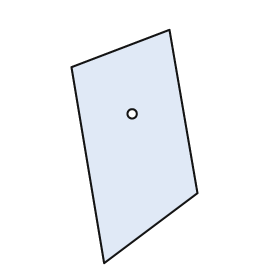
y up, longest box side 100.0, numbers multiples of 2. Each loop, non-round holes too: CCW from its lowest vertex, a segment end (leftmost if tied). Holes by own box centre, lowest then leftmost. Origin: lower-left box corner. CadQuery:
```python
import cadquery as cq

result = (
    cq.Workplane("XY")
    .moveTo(14.0, 0.0)
    .lineTo(54.0, 30.0)
    .lineTo(42.0, 100.0)
    .lineTo(0.0, 84.0)
    .close()
    .moveTo(26.0, 64.0)
    .circle(2.0)
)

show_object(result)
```